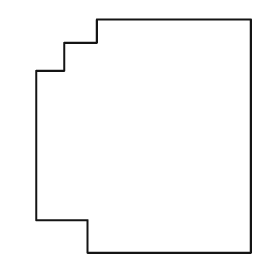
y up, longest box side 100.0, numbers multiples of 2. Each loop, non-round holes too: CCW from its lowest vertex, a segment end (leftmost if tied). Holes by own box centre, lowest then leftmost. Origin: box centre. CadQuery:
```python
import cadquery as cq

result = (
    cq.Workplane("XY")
    .moveTo(-24.0, -50.0)
    .lineTo(46.0, -50.0)
    .lineTo(46.0, 50.0)
    .lineTo(-20.0, 50.0)
    .lineTo(-20.0, 40.0)
    .lineTo(-34.0, 40.0)
    .lineTo(-34.0, 28.0)
    .lineTo(-46.0, 28.0)
    .lineTo(-46.0, -36.0)
    .lineTo(-24.0, -36.0)
    .close()
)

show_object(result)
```